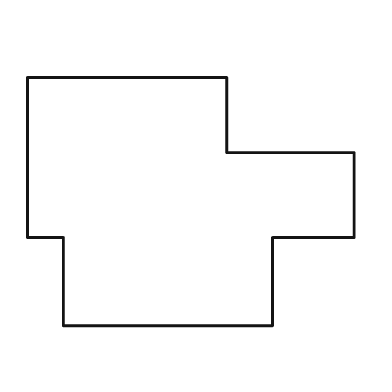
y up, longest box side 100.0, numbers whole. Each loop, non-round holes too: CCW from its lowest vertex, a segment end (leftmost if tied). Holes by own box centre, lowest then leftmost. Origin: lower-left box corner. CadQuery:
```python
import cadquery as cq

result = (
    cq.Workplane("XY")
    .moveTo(11.0, 0.0)
    .lineTo(75.0, 0.0)
    .lineTo(75.0, 27.0)
    .lineTo(100.0, 27.0)
    .lineTo(100.0, 53.0)
    .lineTo(61.0, 53.0)
    .lineTo(61.0, 76.0)
    .lineTo(0.0, 76.0)
    .lineTo(0.0, 27.0)
    .lineTo(11.0, 27.0)
    .close()
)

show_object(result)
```